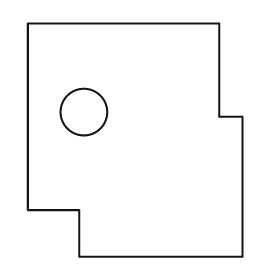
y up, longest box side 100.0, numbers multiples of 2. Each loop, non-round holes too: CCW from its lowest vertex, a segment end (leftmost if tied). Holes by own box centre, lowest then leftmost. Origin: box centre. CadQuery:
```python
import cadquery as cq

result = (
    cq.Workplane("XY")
    .moveTo(-24.0, -50.0)
    .lineTo(46.0, -50.0)
    .lineTo(46.0, 10.0)
    .lineTo(36.0, 10.0)
    .lineTo(36.0, 50.0)
    .lineTo(-46.0, 50.0)
    .lineTo(-46.0, -30.0)
    .lineTo(-24.0, -30.0)
    .close()
    .moveTo(-22.0, 12.0)
    .circle(10.0)
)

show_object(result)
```